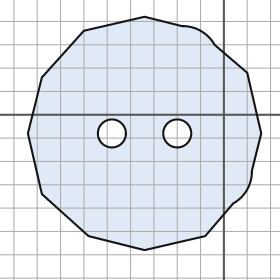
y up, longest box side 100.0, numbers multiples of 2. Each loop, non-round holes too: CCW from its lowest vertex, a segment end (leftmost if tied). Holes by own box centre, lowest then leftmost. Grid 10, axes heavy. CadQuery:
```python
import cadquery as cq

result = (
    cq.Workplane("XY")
    .moveTo(-34.0, -58.0)
    .lineTo(-8.0, -52.0)
    .lineTo(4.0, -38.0)
    .threePointArc((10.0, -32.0), (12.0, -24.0))
    .lineTo(16.0, -8.0)
    .lineTo(10.0, 18.0)
    .lineTo(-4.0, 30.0)
    .threePointArc((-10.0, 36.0), (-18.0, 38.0))
    .lineTo(-34.0, 42.0)
    .lineTo(-60.0, 36.0)
    .lineTo(-78.0, 16.0)
    .lineTo(-84.0, -8.0)
    .lineTo(-78.0, -34.0)
    .lineTo(-58.0, -52.0)
    .close()
    .moveTo(-48.0, -8.0)
    .circle(6.0)
    .moveTo(-20.0, -8.0)
    .circle(6.0)
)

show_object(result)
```